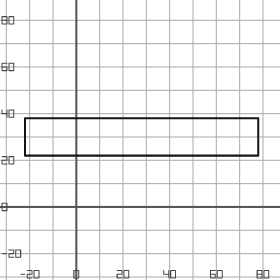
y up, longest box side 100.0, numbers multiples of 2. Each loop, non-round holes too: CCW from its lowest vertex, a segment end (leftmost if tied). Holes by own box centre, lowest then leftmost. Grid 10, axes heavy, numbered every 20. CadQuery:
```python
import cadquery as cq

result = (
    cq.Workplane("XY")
    .moveTo(-22.0, 22.0)
    .lineTo(78.0, 22.0)
    .lineTo(78.0, 38.0)
    .lineTo(-22.0, 38.0)
    .close()
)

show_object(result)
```